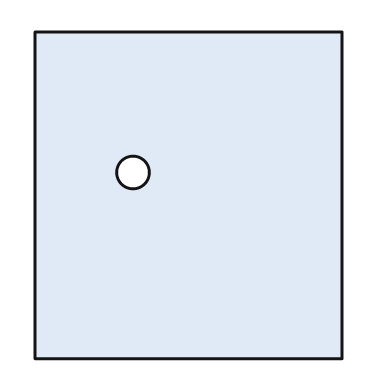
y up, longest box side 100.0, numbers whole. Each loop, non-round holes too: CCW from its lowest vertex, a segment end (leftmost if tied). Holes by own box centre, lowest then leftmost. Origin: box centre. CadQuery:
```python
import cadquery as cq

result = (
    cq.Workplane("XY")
    .moveTo(-47.0, -50.0)
    .lineTo(47.0, -50.0)
    .lineTo(47.0, 50.0)
    .lineTo(-47.0, 50.0)
    .close()
    .moveTo(-17.0, 7.0)
    .circle(5.0)
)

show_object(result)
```